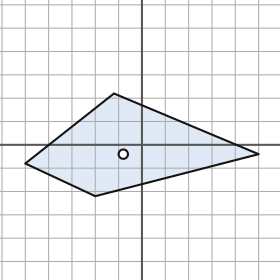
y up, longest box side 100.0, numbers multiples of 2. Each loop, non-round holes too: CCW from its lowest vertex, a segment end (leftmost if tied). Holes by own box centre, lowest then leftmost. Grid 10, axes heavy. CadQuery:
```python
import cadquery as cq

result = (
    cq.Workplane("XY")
    .moveTo(-20.0, -22.0)
    .lineTo(50.0, -4.0)
    .lineTo(-12.0, 22.0)
    .lineTo(-50.0, -8.0)
    .close()
    .moveTo(-8.0, -4.0)
    .circle(2.0)
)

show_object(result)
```